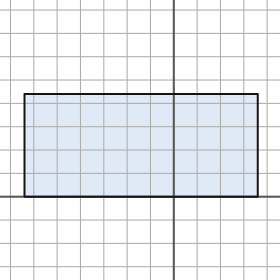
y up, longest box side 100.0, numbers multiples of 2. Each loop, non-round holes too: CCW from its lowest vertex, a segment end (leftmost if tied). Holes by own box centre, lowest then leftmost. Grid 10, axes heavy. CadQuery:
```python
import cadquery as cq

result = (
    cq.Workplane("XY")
    .moveTo(-64.0, 0.0)
    .lineTo(36.0, 0.0)
    .lineTo(36.0, 44.0)
    .lineTo(-64.0, 44.0)
    .close()
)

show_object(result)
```